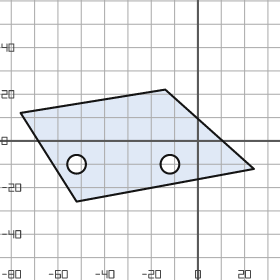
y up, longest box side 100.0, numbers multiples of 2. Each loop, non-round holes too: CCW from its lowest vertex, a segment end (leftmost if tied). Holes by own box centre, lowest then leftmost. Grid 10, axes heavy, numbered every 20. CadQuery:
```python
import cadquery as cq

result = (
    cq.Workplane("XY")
    .moveTo(-52.0, -26.0)
    .lineTo(24.0, -12.0)
    .lineTo(-14.0, 22.0)
    .lineTo(-76.0, 12.0)
    .close()
    .moveTo(-52.0, -10.0)
    .circle(4.0)
    .moveTo(-12.0, -10.0)
    .circle(4.0)
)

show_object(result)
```